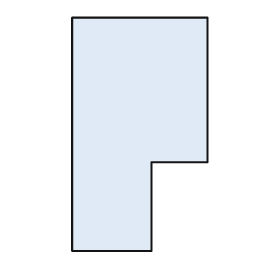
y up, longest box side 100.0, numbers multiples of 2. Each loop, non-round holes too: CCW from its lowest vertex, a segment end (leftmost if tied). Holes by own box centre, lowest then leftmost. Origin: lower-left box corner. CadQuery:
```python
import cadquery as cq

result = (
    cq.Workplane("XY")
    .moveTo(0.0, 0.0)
    .lineTo(34.0, 0.0)
    .lineTo(34.0, 38.0)
    .lineTo(58.0, 38.0)
    .lineTo(58.0, 100.0)
    .lineTo(0.0, 100.0)
    .close()
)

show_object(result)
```